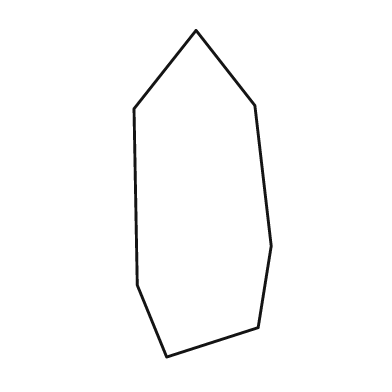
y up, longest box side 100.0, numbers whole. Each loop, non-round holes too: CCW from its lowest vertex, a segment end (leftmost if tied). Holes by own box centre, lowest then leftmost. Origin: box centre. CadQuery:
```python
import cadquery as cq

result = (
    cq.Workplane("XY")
    .moveTo(-11.0, -50.0)
    .lineTo(17.0, -41.0)
    .lineTo(21.0, -16.0)
    .lineTo(16.0, 27.0)
    .lineTo(-2.0, 50.0)
    .lineTo(-21.0, 26.0)
    .lineTo(-20.0, -28.0)
    .close()
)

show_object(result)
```